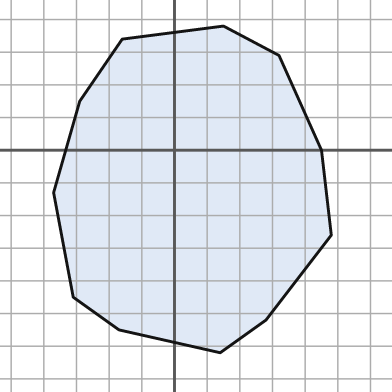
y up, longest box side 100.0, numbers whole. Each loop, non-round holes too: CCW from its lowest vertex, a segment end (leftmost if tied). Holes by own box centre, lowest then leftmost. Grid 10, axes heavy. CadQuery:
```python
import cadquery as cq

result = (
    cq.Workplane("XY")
    .moveTo(14.0, -62.0)
    .lineTo(28.0, -52.0)
    .lineTo(48.0, -26.0)
    .lineTo(45.0, 0.0)
    .lineTo(32.0, 29.0)
    .lineTo(15.0, 38.0)
    .lineTo(-16.0, 34.0)
    .lineTo(-29.0, 15.0)
    .lineTo(-37.0, -13.0)
    .lineTo(-31.0, -45.0)
    .lineTo(-17.0, -55.0)
    .close()
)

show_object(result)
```